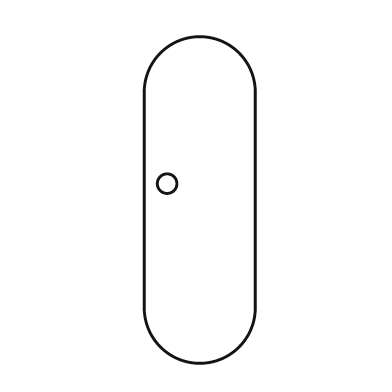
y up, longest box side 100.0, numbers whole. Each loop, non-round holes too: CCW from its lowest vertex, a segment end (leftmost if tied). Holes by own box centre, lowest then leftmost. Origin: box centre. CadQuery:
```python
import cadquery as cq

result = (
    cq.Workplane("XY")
    .moveTo(-17.0, -33.0)
    .threePointArc((0.0, -50.0), (17.0, -33.0))
    .lineTo(17.0, 33.0)
    .threePointArc((0.0, 50.0), (-17.0, 33.0))
    .close()
    .moveTo(-10.0, 5.0)
    .circle(3.0)
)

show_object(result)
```